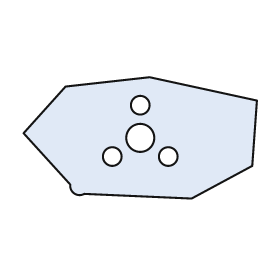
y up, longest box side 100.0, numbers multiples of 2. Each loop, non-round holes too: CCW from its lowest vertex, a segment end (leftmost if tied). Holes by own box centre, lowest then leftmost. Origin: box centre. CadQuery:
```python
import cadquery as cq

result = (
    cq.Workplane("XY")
    .moveTo(22.0, -26.0)
    .lineTo(48.0, -12.0)
    .lineTo(50.0, 16.0)
    .lineTo(4.0, 26.0)
    .lineTo(-32.0, 22.0)
    .lineTo(-50.0, 2.0)
    .lineTo(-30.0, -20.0)
    .threePointArc((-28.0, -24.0), (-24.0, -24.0))
    .close()
    .moveTo(-12.0, -8.0)
    .circle(4.0)
    .moveTo(12.0, -8.0)
    .circle(4.0)
    .moveTo(0.0, 0.0)
    .circle(6.0)
    .moveTo(0.0, 14.0)
    .circle(4.0)
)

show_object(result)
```